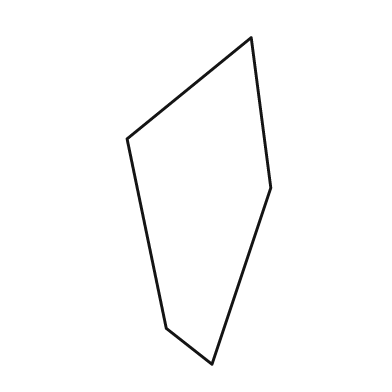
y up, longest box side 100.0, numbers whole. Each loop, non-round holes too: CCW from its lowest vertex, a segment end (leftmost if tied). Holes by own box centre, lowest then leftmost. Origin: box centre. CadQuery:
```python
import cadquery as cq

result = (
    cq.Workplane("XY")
    .moveTo(4.0, -50.0)
    .lineTo(22.0, 4.0)
    .lineTo(16.0, 50.0)
    .lineTo(-22.0, 19.0)
    .lineTo(-10.0, -39.0)
    .close()
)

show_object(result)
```